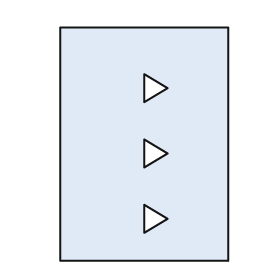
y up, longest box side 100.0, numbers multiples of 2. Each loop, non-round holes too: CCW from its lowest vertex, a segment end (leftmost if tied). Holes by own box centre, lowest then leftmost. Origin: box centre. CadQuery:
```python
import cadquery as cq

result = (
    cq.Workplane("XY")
    .moveTo(-36.0, -50.0)
    .lineTo(36.0, -50.0)
    .lineTo(36.0, 50.0)
    .lineTo(-36.0, 50.0)
    .close()
    .moveTo(0.0, -38.0)
    .lineTo(10.0, -32.0)
    .lineTo(0.0, -26.0)
    .close()
    .moveTo(0.0, -10.0)
    .lineTo(10.0, -4.0)
    .lineTo(0.0, 2.0)
    .close()
    .moveTo(0.0, 18.0)
    .lineTo(10.0, 24.0)
    .lineTo(0.0, 30.0)
    .close()
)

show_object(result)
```